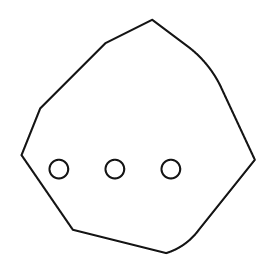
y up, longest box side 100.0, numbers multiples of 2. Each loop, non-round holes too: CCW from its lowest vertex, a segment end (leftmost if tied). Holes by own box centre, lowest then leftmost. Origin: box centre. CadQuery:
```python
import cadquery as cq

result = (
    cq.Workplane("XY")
    .moveTo(12.0, -50.0)
    .threePointArc((20.0, -46.0), (26.0, -40.0))
    .lineTo(50.0, -10.0)
    .lineTo(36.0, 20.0)
    .threePointArc((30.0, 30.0), (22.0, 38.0))
    .lineTo(6.0, 50.0)
    .lineTo(-14.0, 40.0)
    .lineTo(-42.0, 12.0)
    .lineTo(-50.0, -8.0)
    .lineTo(-28.0, -40.0)
    .close()
    .moveTo(-34.0, -14.0)
    .circle(4.0)
    .moveTo(-10.0, -14.0)
    .circle(4.0)
    .moveTo(14.0, -14.0)
    .circle(4.0)
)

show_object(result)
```